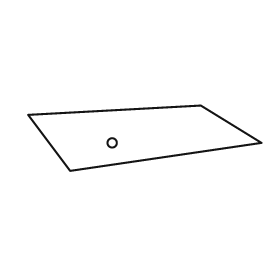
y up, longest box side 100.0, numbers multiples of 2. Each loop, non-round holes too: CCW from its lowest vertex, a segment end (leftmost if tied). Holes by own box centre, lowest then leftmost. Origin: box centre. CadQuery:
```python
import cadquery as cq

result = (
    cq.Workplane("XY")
    .moveTo(-32.0, -14.0)
    .lineTo(50.0, -2.0)
    .lineTo(24.0, 14.0)
    .lineTo(-50.0, 10.0)
    .close()
    .moveTo(-14.0, -2.0)
    .circle(2.0)
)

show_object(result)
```